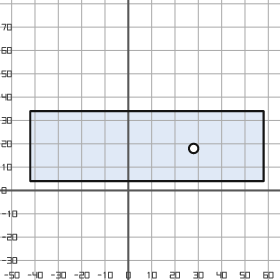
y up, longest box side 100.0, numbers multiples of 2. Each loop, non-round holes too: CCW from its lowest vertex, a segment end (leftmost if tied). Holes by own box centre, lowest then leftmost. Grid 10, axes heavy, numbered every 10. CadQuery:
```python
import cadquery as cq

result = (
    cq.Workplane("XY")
    .moveTo(-42.0, 4.0)
    .lineTo(58.0, 4.0)
    .lineTo(58.0, 34.0)
    .lineTo(-42.0, 34.0)
    .close()
    .moveTo(28.0, 18.0)
    .circle(2.0)
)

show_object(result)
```